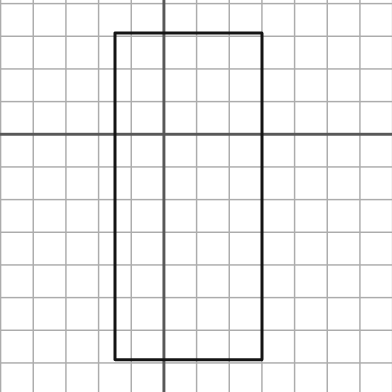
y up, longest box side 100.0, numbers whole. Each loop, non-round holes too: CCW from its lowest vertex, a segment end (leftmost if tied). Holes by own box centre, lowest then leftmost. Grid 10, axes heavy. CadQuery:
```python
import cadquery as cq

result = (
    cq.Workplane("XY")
    .moveTo(-15.0, -69.0)
    .lineTo(30.0, -69.0)
    .lineTo(30.0, 31.0)
    .lineTo(-15.0, 31.0)
    .close()
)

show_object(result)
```